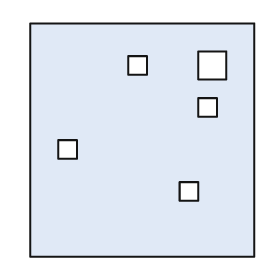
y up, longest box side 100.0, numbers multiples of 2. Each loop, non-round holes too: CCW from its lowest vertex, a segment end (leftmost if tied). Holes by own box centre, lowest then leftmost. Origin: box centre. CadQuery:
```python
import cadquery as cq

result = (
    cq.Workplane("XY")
    .moveTo(-48.0, -50.0)
    .lineTo(48.0, -50.0)
    .lineTo(48.0, 50.0)
    .lineTo(-48.0, 50.0)
    .close()
    .moveTo(16.0, -26.0)
    .lineTo(24.0, -26.0)
    .lineTo(24.0, -18.0)
    .lineTo(16.0, -18.0)
    .close()
    .moveTo(-36.0, -8.0)
    .lineTo(-28.0, -8.0)
    .lineTo(-28.0, 0.0)
    .lineTo(-36.0, 0.0)
    .close()
    .moveTo(24.0, 10.0)
    .lineTo(32.0, 10.0)
    .lineTo(32.0, 18.0)
    .lineTo(24.0, 18.0)
    .close()
    .moveTo(-6.0, 28.0)
    .lineTo(2.0, 28.0)
    .lineTo(2.0, 36.0)
    .lineTo(-6.0, 36.0)
    .close()
    .moveTo(24.0, 26.0)
    .lineTo(36.0, 26.0)
    .lineTo(36.0, 38.0)
    .lineTo(24.0, 38.0)
    .close()
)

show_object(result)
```